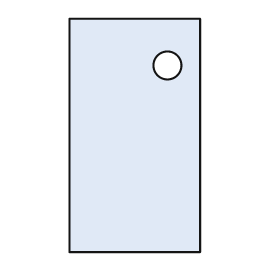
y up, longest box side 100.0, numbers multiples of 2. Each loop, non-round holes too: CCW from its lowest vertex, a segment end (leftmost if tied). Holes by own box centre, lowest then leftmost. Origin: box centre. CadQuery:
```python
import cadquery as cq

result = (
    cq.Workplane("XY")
    .moveTo(-28.0, -50.0)
    .lineTo(28.0, -50.0)
    .lineTo(28.0, 50.0)
    .lineTo(-28.0, 50.0)
    .close()
    .moveTo(14.0, 30.0)
    .circle(6.0)
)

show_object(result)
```